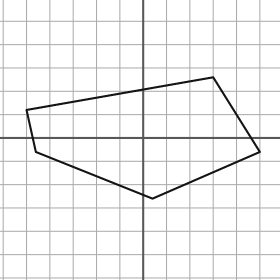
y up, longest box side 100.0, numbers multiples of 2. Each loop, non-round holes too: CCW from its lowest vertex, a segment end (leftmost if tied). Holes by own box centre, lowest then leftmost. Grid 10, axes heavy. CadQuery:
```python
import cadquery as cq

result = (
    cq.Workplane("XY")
    .moveTo(4.0, -26.0)
    .lineTo(50.0, -6.0)
    .lineTo(30.0, 26.0)
    .lineTo(-50.0, 12.0)
    .lineTo(-46.0, -6.0)
    .close()
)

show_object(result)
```